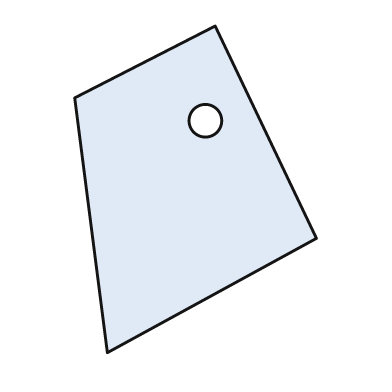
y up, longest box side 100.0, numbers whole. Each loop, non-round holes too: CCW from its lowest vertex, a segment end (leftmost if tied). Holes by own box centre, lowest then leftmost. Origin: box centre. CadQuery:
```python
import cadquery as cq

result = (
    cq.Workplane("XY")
    .moveTo(-27.0, -50.0)
    .lineTo(37.0, -15.0)
    .lineTo(6.0, 50.0)
    .lineTo(-37.0, 28.0)
    .close()
    .moveTo(3.0, 21.0)
    .circle(5.0)
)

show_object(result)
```